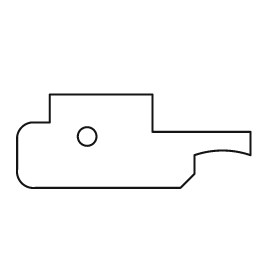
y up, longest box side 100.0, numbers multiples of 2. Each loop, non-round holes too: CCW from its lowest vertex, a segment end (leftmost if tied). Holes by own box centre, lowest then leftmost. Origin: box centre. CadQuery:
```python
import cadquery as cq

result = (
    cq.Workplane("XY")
    .moveTo(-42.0, -20.0)
    .lineTo(20.0, -20.0)
    .lineTo(26.0, -14.0)
    .lineTo(26.0, -6.0)
    .threePointArc((38.0, -4.0), (50.0, -6.0))
    .lineTo(50.0, 4.0)
    .lineTo(8.0, 4.0)
    .lineTo(8.0, 20.0)
    .lineTo(-36.0, 20.0)
    .lineTo(-36.0, 8.0)
    .lineTo(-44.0, 8.0)
    .threePointArc((-48.0, 6.0), (-50.0, 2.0))
    .lineTo(-50.0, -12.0)
    .threePointArc((-48.0, -18.0), (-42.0, -20.0))
    .close()
    .moveTo(-20.0, 2.0)
    .circle(4.0)
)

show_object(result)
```